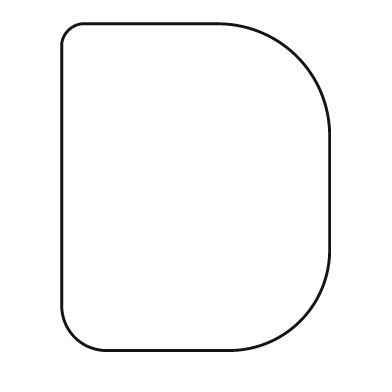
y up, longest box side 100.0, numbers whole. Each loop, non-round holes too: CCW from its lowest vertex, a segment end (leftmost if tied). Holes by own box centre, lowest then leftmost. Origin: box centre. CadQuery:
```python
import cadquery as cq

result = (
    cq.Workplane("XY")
    .moveTo(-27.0, -50.0)
    .lineTo(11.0, -50.0)
    .threePointArc((32.0, -41.0), (41.0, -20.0))
    .lineTo(41.0, 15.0)
    .threePointArc((31.0, 40.0), (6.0, 50.0))
    .lineTo(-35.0, 50.0)
    .threePointArc((-39.0, 48.0), (-41.0, 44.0))
    .lineTo(-41.0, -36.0)
    .threePointArc((-37.0, -46.0), (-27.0, -50.0))
    .close()
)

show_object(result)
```